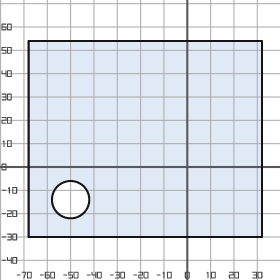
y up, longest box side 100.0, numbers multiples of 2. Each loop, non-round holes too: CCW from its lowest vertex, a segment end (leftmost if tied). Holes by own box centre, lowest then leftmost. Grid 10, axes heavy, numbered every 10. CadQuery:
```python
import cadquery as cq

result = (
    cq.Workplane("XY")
    .moveTo(-68.0, -30.0)
    .lineTo(32.0, -30.0)
    .lineTo(32.0, 54.0)
    .lineTo(-68.0, 54.0)
    .close()
    .moveTo(-50.0, -14.0)
    .circle(8.0)
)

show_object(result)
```